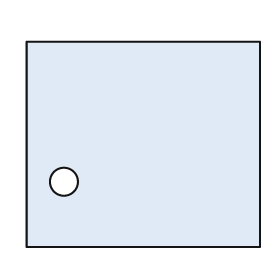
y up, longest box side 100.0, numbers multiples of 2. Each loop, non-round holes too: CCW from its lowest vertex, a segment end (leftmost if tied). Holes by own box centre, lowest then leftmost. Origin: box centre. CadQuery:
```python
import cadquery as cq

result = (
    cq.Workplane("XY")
    .moveTo(-50.0, -44.0)
    .lineTo(50.0, -44.0)
    .lineTo(50.0, 44.0)
    .lineTo(-50.0, 44.0)
    .close()
    .moveTo(-34.0, -16.0)
    .circle(6.0)
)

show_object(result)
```